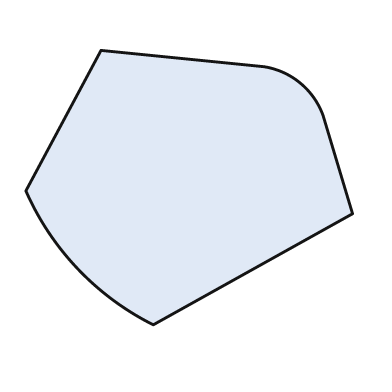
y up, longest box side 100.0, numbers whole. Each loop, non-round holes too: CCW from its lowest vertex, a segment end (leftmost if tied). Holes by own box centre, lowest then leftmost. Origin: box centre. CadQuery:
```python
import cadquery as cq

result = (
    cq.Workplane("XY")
    .moveTo(-11.0, -42.0)
    .lineTo(50.0, -8.0)
    .lineTo(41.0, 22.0)
    .threePointArc((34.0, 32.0), (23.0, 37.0))
    .lineTo(-27.0, 42.0)
    .lineTo(-50.0, -1.0)
    .threePointArc((-34.0, -25.0), (-11.0, -42.0))
    .close()
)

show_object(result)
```